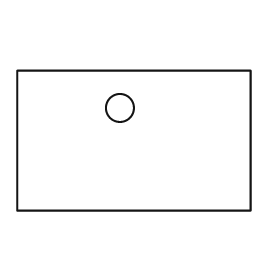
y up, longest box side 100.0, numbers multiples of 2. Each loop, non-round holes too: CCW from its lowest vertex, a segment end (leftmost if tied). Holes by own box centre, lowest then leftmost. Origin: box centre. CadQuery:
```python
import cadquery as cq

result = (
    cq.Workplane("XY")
    .moveTo(-50.0, -30.0)
    .lineTo(50.0, -30.0)
    .lineTo(50.0, 30.0)
    .lineTo(-50.0, 30.0)
    .close()
    .moveTo(-6.0, 14.0)
    .circle(6.0)
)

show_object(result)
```